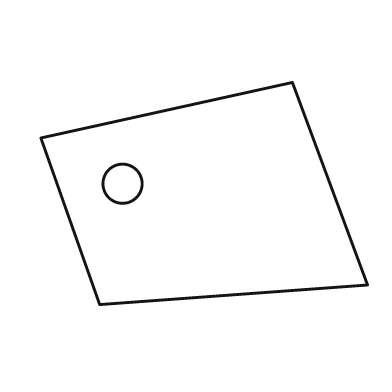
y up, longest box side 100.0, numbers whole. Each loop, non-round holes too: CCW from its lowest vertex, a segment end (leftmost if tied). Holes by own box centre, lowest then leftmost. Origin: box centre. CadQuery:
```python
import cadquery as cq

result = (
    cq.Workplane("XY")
    .moveTo(-32.0, -34.0)
    .lineTo(50.0, -28.0)
    .lineTo(27.0, 34.0)
    .lineTo(-50.0, 17.0)
    .close()
    .moveTo(-25.0, 3.0)
    .circle(6.0)
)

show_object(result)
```